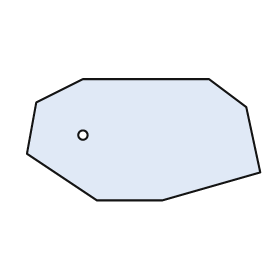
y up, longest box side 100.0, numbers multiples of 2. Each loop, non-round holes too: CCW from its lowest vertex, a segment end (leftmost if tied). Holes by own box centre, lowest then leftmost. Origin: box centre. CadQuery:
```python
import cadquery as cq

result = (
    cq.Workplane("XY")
    .moveTo(-20.0, -26.0)
    .lineTo(8.0, -26.0)
    .lineTo(50.0, -14.0)
    .lineTo(44.0, 14.0)
    .lineTo(28.0, 26.0)
    .lineTo(-26.0, 26.0)
    .lineTo(-46.0, 16.0)
    .lineTo(-50.0, -6.0)
    .close()
    .moveTo(-26.0, 2.0)
    .circle(2.0)
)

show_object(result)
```